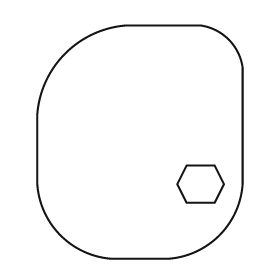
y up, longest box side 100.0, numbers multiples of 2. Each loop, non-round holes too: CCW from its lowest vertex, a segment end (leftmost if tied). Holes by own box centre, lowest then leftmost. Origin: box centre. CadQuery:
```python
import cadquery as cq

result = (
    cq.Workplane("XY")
    .moveTo(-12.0, -50.0)
    .lineTo(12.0, -50.0)
    .threePointArc((34.0, -40.0), (44.0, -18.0))
    .lineTo(44.0, 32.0)
    .threePointArc((38.0, 44.0), (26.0, 50.0))
    .lineTo(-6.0, 50.0)
    .threePointArc((-32.0, 38.0), (-44.0, 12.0))
    .lineTo(-44.0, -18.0)
    .threePointArc((-34.0, -40.0), (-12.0, -50.0))
    .close()
    .moveTo(20.0, -26.0)
    .lineTo(32.0, -26.0)
    .lineTo(36.0, -18.0)
    .lineTo(32.0, -10.0)
    .lineTo(20.0, -10.0)
    .lineTo(16.0, -18.0)
    .close()
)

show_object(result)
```